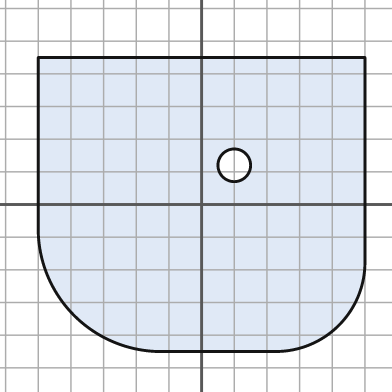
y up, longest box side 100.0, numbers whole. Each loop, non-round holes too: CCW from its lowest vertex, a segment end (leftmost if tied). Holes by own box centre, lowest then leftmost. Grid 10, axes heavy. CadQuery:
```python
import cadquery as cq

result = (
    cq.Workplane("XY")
    .moveTo(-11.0, -45.0)
    .lineTo(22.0, -45.0)
    .threePointArc((42.0, -37.0), (50.0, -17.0))
    .lineTo(50.0, 45.0)
    .lineTo(-50.0, 45.0)
    .lineTo(-50.0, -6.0)
    .threePointArc((-39.0, -34.0), (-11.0, -45.0))
    .close()
    .moveTo(10.0, 12.0)
    .circle(5.0)
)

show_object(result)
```